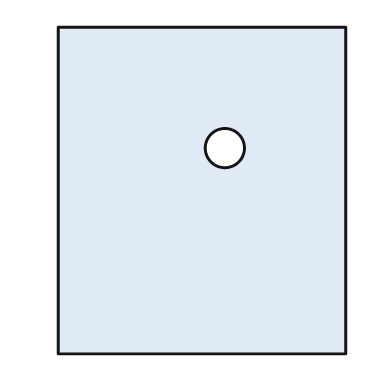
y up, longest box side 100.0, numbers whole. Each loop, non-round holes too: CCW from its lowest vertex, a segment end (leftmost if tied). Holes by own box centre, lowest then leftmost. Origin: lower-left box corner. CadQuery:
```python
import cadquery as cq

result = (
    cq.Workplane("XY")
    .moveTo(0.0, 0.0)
    .lineTo(88.0, 0.0)
    .lineTo(88.0, 100.0)
    .lineTo(0.0, 100.0)
    .close()
    .moveTo(51.0, 63.0)
    .circle(6.0)
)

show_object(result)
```